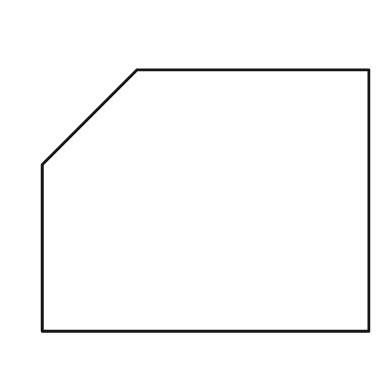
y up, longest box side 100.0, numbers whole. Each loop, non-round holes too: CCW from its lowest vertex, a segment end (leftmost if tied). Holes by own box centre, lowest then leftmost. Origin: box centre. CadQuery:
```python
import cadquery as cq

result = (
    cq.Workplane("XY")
    .moveTo(-50.0, -40.0)
    .lineTo(50.0, -40.0)
    .lineTo(50.0, 40.0)
    .lineTo(-21.0, 40.0)
    .lineTo(-50.0, 11.0)
    .close()
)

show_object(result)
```